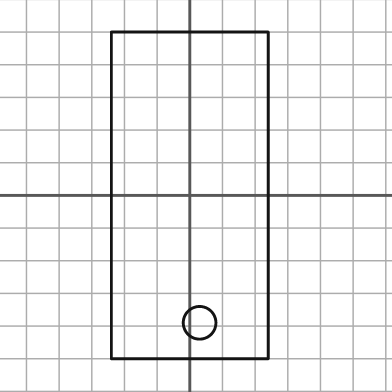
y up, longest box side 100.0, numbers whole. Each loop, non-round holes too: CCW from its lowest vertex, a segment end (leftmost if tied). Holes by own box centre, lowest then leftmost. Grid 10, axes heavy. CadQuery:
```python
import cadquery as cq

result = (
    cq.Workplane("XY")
    .moveTo(-24.0, -50.0)
    .lineTo(24.0, -50.0)
    .lineTo(24.0, 50.0)
    .lineTo(-24.0, 50.0)
    .close()
    .moveTo(3.0, -39.0)
    .circle(5.0)
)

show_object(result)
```